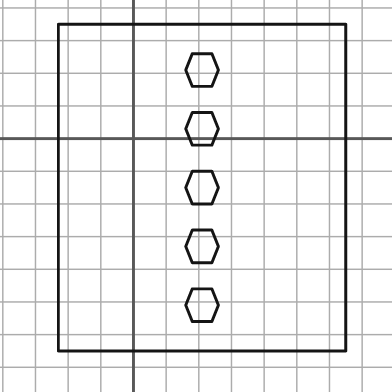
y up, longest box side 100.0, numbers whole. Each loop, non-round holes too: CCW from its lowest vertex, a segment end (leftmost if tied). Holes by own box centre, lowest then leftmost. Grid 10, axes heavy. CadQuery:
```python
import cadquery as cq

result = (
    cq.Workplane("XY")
    .moveTo(-23.0, -65.0)
    .lineTo(65.0, -65.0)
    .lineTo(65.0, 35.0)
    .lineTo(-23.0, 35.0)
    .close()
    .moveTo(18.0, -56.0)
    .lineTo(24.0, -56.0)
    .lineTo(26.0, -51.0)
    .lineTo(24.0, -46.0)
    .lineTo(18.0, -46.0)
    .lineTo(16.0, -51.0)
    .close()
    .moveTo(18.0, -38.0)
    .lineTo(24.0, -38.0)
    .lineTo(26.0, -33.0)
    .lineTo(24.0, -28.0)
    .lineTo(18.0, -28.0)
    .lineTo(16.0, -33.0)
    .close()
    .moveTo(18.0, -20.0)
    .lineTo(24.0, -20.0)
    .lineTo(26.0, -15.0)
    .lineTo(24.0, -10.0)
    .lineTo(18.0, -10.0)
    .lineTo(16.0, -15.0)
    .close()
    .moveTo(18.0, -2.0)
    .lineTo(24.0, -2.0)
    .lineTo(26.0, 3.0)
    .lineTo(24.0, 8.0)
    .lineTo(18.0, 8.0)
    .lineTo(16.0, 3.0)
    .close()
    .moveTo(18.0, 16.0)
    .lineTo(24.0, 16.0)
    .lineTo(26.0, 21.0)
    .lineTo(24.0, 26.0)
    .lineTo(18.0, 26.0)
    .lineTo(16.0, 21.0)
    .close()
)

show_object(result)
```